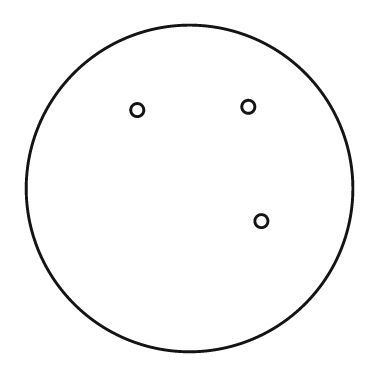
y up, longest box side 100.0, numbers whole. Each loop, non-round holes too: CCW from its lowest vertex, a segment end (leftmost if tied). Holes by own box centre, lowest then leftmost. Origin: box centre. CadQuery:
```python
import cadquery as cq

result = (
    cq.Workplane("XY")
    .moveTo(0.0, 0.0)
    .circle(50.0)
    .moveTo(22.0, -10.0)
    .circle(2.0)
    .moveTo(-16.0, 24.0)
    .circle(2.0)
    .moveTo(18.0, 25.0)
    .circle(2.0)
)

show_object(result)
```